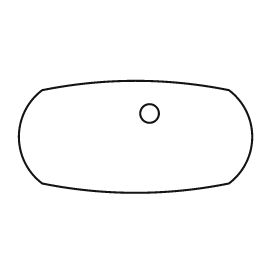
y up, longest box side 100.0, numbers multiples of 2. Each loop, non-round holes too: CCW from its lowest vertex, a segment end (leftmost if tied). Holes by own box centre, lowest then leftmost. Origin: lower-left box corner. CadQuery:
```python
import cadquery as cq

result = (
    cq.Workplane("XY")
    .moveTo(10.0, 4.0)
    .threePointArc((50.0, 0.0), (90.0, 4.0))
    .threePointArc((100.0, 24.0), (90.0, 44.0))
    .threePointArc((50.0, 48.0), (10.0, 44.0))
    .threePointArc((0.0, 24.0), (10.0, 4.0))
    .close()
    .moveTo(56.0, 34.0)
    .circle(4.0)
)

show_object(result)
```